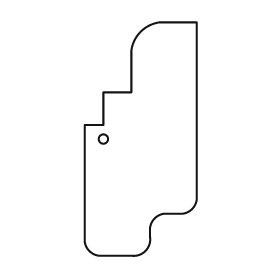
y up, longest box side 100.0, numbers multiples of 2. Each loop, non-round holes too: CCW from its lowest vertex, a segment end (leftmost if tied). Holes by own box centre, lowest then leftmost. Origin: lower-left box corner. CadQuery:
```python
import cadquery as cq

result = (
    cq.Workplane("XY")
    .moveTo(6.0, 0.0)
    .lineTo(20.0, 0.0)
    .threePointArc((26.0, 2.0), (28.0, 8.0))
    .lineTo(28.0, 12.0)
    .threePointArc((30.0, 16.0), (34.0, 18.0))
    .lineTo(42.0, 18.0)
    .threePointArc((46.0, 20.0), (48.0, 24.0))
    .lineTo(48.0, 100.0)
    .lineTo(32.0, 100.0)
    .threePointArc((24.0, 96.0), (20.0, 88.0))
    .lineTo(20.0, 70.0)
    .lineTo(8.0, 70.0)
    .lineTo(8.0, 56.0)
    .lineTo(0.0, 56.0)
    .lineTo(0.0, 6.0)
    .threePointArc((2.0, 2.0), (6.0, 0.0))
    .close()
    .moveTo(8.0, 50.0)
    .circle(2.0)
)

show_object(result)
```